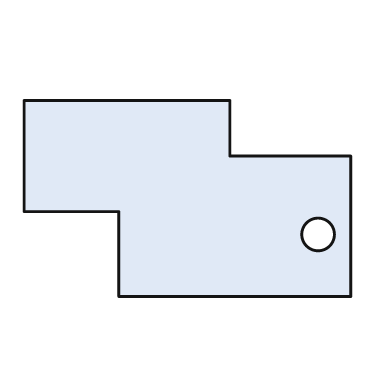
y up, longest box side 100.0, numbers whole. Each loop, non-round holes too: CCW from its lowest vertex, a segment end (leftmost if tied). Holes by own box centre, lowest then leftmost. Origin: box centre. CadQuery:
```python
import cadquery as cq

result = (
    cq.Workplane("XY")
    .moveTo(-21.0, -30.0)
    .lineTo(50.0, -30.0)
    .lineTo(50.0, 13.0)
    .lineTo(13.0, 13.0)
    .lineTo(13.0, 30.0)
    .lineTo(-50.0, 30.0)
    .lineTo(-50.0, -4.0)
    .lineTo(-21.0, -4.0)
    .close()
    .moveTo(40.0, -11.0)
    .circle(5.0)
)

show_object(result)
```